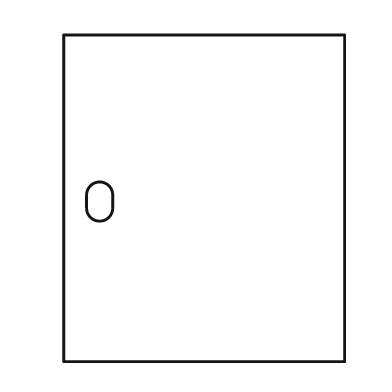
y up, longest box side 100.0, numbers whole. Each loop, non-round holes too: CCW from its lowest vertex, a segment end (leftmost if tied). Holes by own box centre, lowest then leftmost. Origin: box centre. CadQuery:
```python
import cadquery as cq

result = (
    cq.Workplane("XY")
    .moveTo(-43.0, -50.0)
    .lineTo(43.0, -50.0)
    .lineTo(43.0, 50.0)
    .lineTo(-43.0, 50.0)
    .close()
    .moveTo(-36.0, -3.0)
    .threePointArc((-32.0, -7.0), (-28.0, -3.0))
    .lineTo(-28.0, 1.0)
    .threePointArc((-32.0, 5.0), (-36.0, 1.0))
    .close()
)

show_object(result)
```